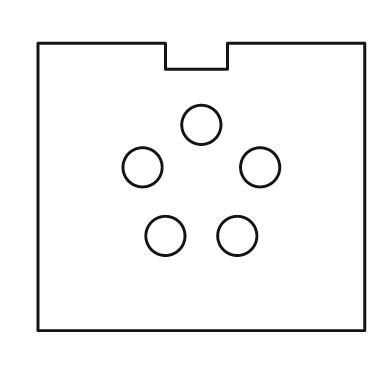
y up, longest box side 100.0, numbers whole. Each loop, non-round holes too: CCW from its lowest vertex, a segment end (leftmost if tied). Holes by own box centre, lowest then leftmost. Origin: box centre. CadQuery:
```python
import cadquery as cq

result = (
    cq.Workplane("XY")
    .moveTo(-50.0, -44.0)
    .lineTo(50.0, -44.0)
    .lineTo(50.0, 44.0)
    .lineTo(8.0, 44.0)
    .lineTo(8.0, 36.0)
    .lineTo(-11.0, 36.0)
    .lineTo(-11.0, 44.0)
    .lineTo(-50.0, 44.0)
    .close()
    .moveTo(-11.0, -15.0)
    .circle(6.0)
    .moveTo(11.0, -15.0)
    .circle(6.0)
    .moveTo(-18.0, 6.0)
    .circle(6.0)
    .moveTo(18.0, 6.0)
    .circle(6.0)
    .moveTo(0.0, 19.0)
    .circle(6.0)
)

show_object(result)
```